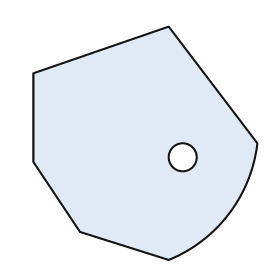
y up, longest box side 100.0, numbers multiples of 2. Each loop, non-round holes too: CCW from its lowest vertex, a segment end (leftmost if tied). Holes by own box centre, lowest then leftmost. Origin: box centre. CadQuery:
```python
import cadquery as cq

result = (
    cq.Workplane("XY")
    .moveTo(10.0, -50.0)
    .threePointArc((36.0, -30.0), (48.0, 0.0))
    .lineTo(10.0, 50.0)
    .lineTo(-48.0, 30.0)
    .lineTo(-48.0, -8.0)
    .lineTo(-28.0, -38.0)
    .close()
    .moveTo(16.0, -6.0)
    .circle(6.0)
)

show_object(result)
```